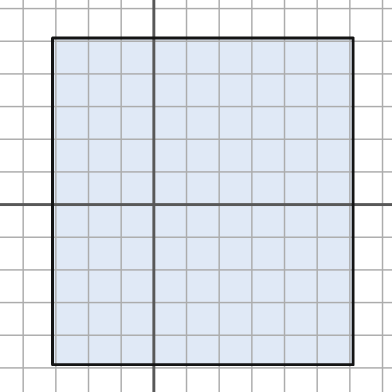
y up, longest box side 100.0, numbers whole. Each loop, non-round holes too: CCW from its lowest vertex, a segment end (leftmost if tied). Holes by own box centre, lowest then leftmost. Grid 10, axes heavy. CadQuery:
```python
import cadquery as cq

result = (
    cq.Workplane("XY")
    .moveTo(-31.0, -49.0)
    .lineTo(61.0, -49.0)
    .lineTo(61.0, 51.0)
    .lineTo(-31.0, 51.0)
    .close()
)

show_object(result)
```